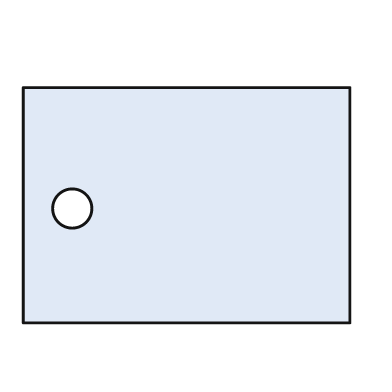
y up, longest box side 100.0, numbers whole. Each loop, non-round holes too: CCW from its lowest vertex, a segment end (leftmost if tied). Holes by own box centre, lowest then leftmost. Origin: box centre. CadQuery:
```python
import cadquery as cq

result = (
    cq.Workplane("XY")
    .moveTo(-50.0, -36.0)
    .lineTo(50.0, -36.0)
    .lineTo(50.0, 36.0)
    .lineTo(-50.0, 36.0)
    .close()
    .moveTo(-35.0, -1.0)
    .circle(6.0)
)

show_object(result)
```